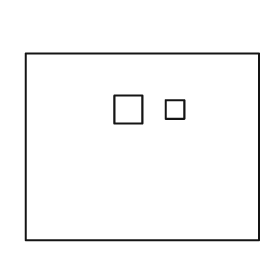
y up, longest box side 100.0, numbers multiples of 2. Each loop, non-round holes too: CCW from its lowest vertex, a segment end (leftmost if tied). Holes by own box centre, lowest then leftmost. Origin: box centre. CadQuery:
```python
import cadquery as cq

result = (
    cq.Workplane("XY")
    .moveTo(-50.0, -40.0)
    .lineTo(50.0, -40.0)
    .lineTo(50.0, 40.0)
    .lineTo(-50.0, 40.0)
    .close()
    .moveTo(-12.0, 10.0)
    .lineTo(0.0, 10.0)
    .lineTo(0.0, 22.0)
    .lineTo(-12.0, 22.0)
    .close()
    .moveTo(10.0, 12.0)
    .lineTo(18.0, 12.0)
    .lineTo(18.0, 20.0)
    .lineTo(10.0, 20.0)
    .close()
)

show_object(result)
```